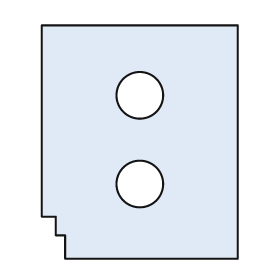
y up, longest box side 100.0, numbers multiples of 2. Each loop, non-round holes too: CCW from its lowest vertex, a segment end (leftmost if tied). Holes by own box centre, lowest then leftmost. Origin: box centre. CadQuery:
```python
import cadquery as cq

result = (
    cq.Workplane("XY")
    .moveTo(-32.0, -50.0)
    .lineTo(42.0, -50.0)
    .lineTo(42.0, 50.0)
    .lineTo(-42.0, 50.0)
    .lineTo(-42.0, -32.0)
    .lineTo(-36.0, -32.0)
    .lineTo(-36.0, -40.0)
    .lineTo(-32.0, -40.0)
    .close()
    .moveTo(0.0, -18.0)
    .circle(10.0)
    .moveTo(0.0, 20.0)
    .circle(10.0)
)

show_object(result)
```